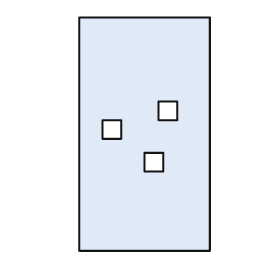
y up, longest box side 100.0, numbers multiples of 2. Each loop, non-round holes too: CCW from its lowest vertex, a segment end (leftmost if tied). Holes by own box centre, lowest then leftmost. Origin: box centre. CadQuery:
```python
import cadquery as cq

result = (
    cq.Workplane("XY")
    .moveTo(-28.0, -50.0)
    .lineTo(28.0, -50.0)
    .lineTo(28.0, 50.0)
    .lineTo(-28.0, 50.0)
    .close()
    .moveTo(0.0, -16.0)
    .lineTo(8.0, -16.0)
    .lineTo(8.0, -8.0)
    .lineTo(0.0, -8.0)
    .close()
    .moveTo(-18.0, -2.0)
    .lineTo(-10.0, -2.0)
    .lineTo(-10.0, 6.0)
    .lineTo(-18.0, 6.0)
    .close()
    .moveTo(6.0, 6.0)
    .lineTo(14.0, 6.0)
    .lineTo(14.0, 14.0)
    .lineTo(6.0, 14.0)
    .close()
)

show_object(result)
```